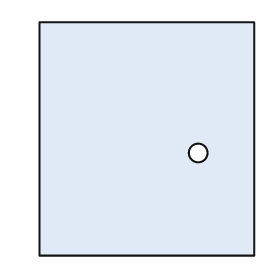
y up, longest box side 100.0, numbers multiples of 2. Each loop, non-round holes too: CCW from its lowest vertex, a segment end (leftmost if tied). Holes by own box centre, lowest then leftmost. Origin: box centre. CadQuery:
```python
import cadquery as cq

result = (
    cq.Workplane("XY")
    .moveTo(-46.0, -50.0)
    .lineTo(46.0, -50.0)
    .lineTo(46.0, 50.0)
    .lineTo(-46.0, 50.0)
    .close()
    .moveTo(22.0, -6.0)
    .circle(4.0)
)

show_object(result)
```